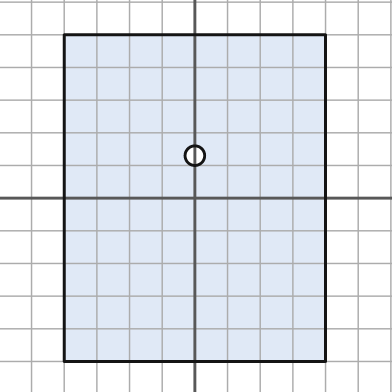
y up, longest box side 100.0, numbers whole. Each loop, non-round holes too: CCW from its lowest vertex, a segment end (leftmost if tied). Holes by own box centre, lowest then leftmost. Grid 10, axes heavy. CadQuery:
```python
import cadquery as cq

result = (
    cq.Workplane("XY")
    .moveTo(-40.0, -50.0)
    .lineTo(40.0, -50.0)
    .lineTo(40.0, 50.0)
    .lineTo(-40.0, 50.0)
    .close()
    .moveTo(0.0, 13.0)
    .circle(3.0)
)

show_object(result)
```